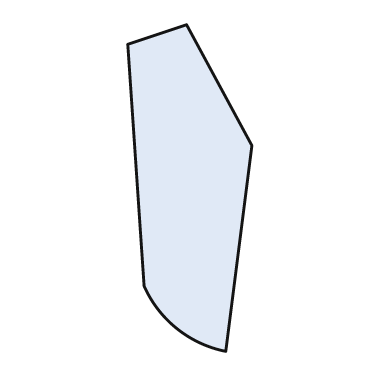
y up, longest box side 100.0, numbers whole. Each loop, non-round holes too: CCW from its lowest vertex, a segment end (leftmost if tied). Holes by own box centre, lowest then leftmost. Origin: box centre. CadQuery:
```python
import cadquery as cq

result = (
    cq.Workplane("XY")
    .moveTo(11.0, -50.0)
    .lineTo(19.0, 13.0)
    .lineTo(-1.0, 50.0)
    .lineTo(-19.0, 44.0)
    .lineTo(-14.0, -30.0)
    .threePointArc((-4.0, -43.0), (11.0, -50.0))
    .close()
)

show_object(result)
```